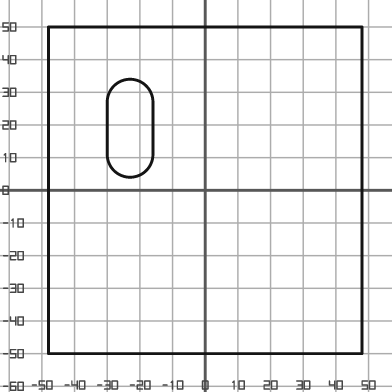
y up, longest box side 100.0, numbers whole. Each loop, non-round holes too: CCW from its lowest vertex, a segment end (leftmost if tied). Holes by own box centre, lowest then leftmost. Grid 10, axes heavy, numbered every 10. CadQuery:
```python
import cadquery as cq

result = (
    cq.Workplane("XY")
    .moveTo(-48.0, -50.0)
    .lineTo(48.0, -50.0)
    .lineTo(48.0, 50.0)
    .lineTo(-48.0, 50.0)
    .close()
    .moveTo(-30.0, 11.0)
    .threePointArc((-23.0, 4.0), (-16.0, 11.0))
    .lineTo(-16.0, 27.0)
    .threePointArc((-23.0, 34.0), (-30.0, 27.0))
    .close()
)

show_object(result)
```